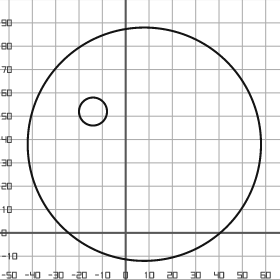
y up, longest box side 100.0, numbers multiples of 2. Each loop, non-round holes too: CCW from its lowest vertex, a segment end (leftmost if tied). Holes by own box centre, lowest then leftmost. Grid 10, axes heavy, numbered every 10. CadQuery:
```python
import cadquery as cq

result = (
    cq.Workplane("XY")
    .moveTo(8.0, 38.0)
    .circle(50.0)
    .moveTo(-14.0, 52.0)
    .circle(6.0)
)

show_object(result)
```